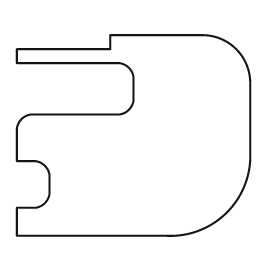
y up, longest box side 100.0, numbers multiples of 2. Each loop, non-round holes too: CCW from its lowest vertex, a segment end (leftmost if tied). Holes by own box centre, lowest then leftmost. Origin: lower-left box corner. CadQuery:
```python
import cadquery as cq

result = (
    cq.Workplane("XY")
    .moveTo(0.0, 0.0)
    .lineTo(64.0, 0.0)
    .threePointArc((90.0, 10.0), (100.0, 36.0))
    .lineTo(100.0, 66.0)
    .threePointArc((94.0, 80.0), (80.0, 86.0))
    .lineTo(40.0, 86.0)
    .lineTo(40.0, 80.0)
    .lineTo(0.0, 80.0)
    .lineTo(0.0, 74.0)
    .lineTo(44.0, 74.0)
    .threePointArc((48.0, 72.0), (50.0, 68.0))
    .lineTo(50.0, 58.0)
    .threePointArc((48.0, 54.0), (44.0, 52.0))
    .lineTo(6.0, 52.0)
    .threePointArc((2.0, 50.0), (0.0, 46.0))
    .lineTo(0.0, 32.0)
    .lineTo(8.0, 32.0)
    .threePointArc((12.0, 30.0), (14.0, 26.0))
    .lineTo(14.0, 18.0)
    .threePointArc((12.0, 14.0), (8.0, 12.0))
    .lineTo(0.0, 12.0)
    .close()
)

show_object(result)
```